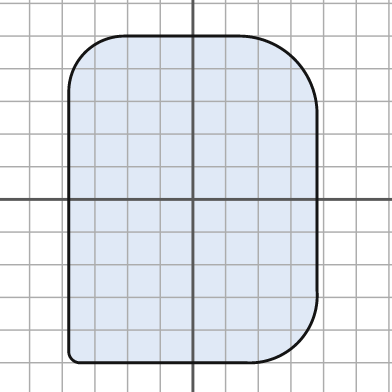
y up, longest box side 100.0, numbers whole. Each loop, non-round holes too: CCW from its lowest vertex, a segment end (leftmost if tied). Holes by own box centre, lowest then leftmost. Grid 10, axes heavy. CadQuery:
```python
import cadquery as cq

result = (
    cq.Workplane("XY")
    .moveTo(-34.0, -50.0)
    .lineTo(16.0, -50.0)
    .threePointArc((32.0, -44.0), (38.0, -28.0))
    .lineTo(38.0, 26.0)
    .threePointArc((31.0, 43.0), (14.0, 50.0))
    .lineTo(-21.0, 50.0)
    .threePointArc((-33.0, 45.0), (-38.0, 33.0))
    .lineTo(-38.0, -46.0)
    .threePointArc((-37.0, -49.0), (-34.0, -50.0))
    .close()
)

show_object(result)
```